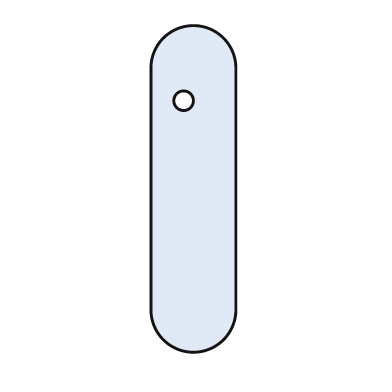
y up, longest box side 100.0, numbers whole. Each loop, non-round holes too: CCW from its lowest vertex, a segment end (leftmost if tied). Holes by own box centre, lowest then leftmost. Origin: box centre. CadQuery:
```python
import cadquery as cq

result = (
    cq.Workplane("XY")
    .moveTo(-13.0, -37.0)
    .threePointArc((0.0, -50.0), (13.0, -37.0))
    .lineTo(13.0, 37.0)
    .threePointArc((0.0, 50.0), (-13.0, 37.0))
    .close()
    .moveTo(-3.0, 27.0)
    .circle(3.0)
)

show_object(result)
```